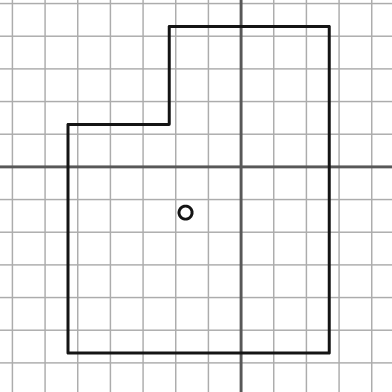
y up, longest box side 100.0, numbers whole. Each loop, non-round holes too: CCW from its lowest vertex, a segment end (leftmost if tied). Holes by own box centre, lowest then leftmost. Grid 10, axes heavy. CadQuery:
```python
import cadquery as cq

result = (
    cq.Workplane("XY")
    .moveTo(-53.0, -57.0)
    .lineTo(27.0, -57.0)
    .lineTo(27.0, 43.0)
    .lineTo(-22.0, 43.0)
    .lineTo(-22.0, 13.0)
    .lineTo(-53.0, 13.0)
    .close()
    .moveTo(-17.0, -14.0)
    .circle(2.0)
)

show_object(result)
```